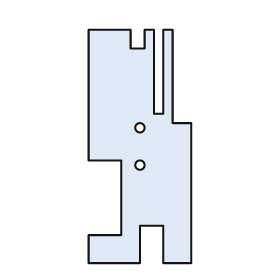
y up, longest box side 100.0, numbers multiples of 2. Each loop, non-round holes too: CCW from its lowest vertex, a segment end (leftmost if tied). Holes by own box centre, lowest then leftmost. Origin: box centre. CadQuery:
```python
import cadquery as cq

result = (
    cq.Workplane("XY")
    .moveTo(-22.0, -50.0)
    .lineTo(0.0, -50.0)
    .lineTo(0.0, -34.0)
    .lineTo(10.0, -34.0)
    .lineTo(10.0, -50.0)
    .lineTo(22.0, -50.0)
    .lineTo(22.0, 10.0)
    .lineTo(14.0, 10.0)
    .lineTo(14.0, 50.0)
    .lineTo(10.0, 50.0)
    .lineTo(10.0, 14.0)
    .lineTo(6.0, 14.0)
    .lineTo(6.0, 50.0)
    .lineTo(2.0, 50.0)
    .lineTo(2.0, 42.0)
    .lineTo(-4.0, 42.0)
    .lineTo(-4.0, 50.0)
    .lineTo(-22.0, 50.0)
    .lineTo(-22.0, -6.0)
    .lineTo(-8.0, -6.0)
    .lineTo(-8.0, -38.0)
    .lineTo(-22.0, -38.0)
    .close()
    .moveTo(0.0, -8.0)
    .circle(2.0)
    .moveTo(0.0, 8.0)
    .circle(2.0)
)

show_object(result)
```